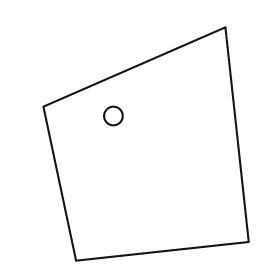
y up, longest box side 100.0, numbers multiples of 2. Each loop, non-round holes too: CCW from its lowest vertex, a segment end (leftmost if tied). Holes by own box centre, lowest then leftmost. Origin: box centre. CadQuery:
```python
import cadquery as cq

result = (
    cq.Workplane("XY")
    .moveTo(-30.0, -50.0)
    .lineTo(44.0, -42.0)
    .lineTo(34.0, 50.0)
    .lineTo(-44.0, 16.0)
    .close()
    .moveTo(-14.0, 12.0)
    .circle(4.0)
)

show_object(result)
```